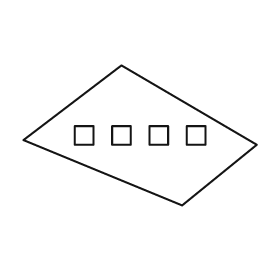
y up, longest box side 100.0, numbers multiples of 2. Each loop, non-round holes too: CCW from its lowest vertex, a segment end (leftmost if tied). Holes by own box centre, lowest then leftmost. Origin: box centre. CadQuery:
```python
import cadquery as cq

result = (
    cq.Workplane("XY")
    .moveTo(18.0, -30.0)
    .lineTo(50.0, -4.0)
    .lineTo(-8.0, 30.0)
    .lineTo(-50.0, -2.0)
    .close()
    .moveTo(-28.0, -4.0)
    .lineTo(-20.0, -4.0)
    .lineTo(-20.0, 4.0)
    .lineTo(-28.0, 4.0)
    .close()
    .moveTo(-12.0, -4.0)
    .lineTo(-4.0, -4.0)
    .lineTo(-4.0, 4.0)
    .lineTo(-12.0, 4.0)
    .close()
    .moveTo(4.0, -4.0)
    .lineTo(12.0, -4.0)
    .lineTo(12.0, 4.0)
    .lineTo(4.0, 4.0)
    .close()
    .moveTo(20.0, -4.0)
    .lineTo(28.0, -4.0)
    .lineTo(28.0, 4.0)
    .lineTo(20.0, 4.0)
    .close()
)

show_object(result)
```